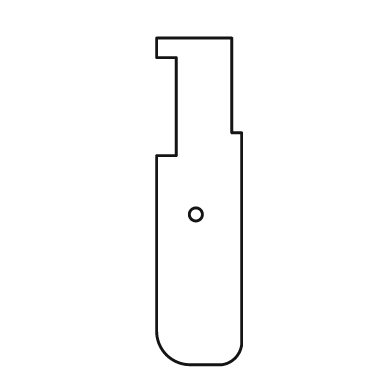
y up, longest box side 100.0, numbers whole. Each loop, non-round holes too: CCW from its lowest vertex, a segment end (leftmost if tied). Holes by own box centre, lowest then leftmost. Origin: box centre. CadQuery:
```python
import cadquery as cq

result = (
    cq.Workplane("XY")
    .moveTo(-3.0, -50.0)
    .lineTo(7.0, -50.0)
    .threePointArc((11.0, -48.0), (13.0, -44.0))
    .lineTo(13.0, 21.0)
    .lineTo(10.0, 21.0)
    .lineTo(10.0, 50.0)
    .lineTo(-13.0, 50.0)
    .lineTo(-13.0, 44.0)
    .lineTo(-7.0, 44.0)
    .lineTo(-7.0, 14.0)
    .lineTo(-13.0, 14.0)
    .lineTo(-13.0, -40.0)
    .threePointArc((-10.0, -47.0), (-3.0, -50.0))
    .close()
    .moveTo(-1.0, -4.0)
    .circle(2.0)
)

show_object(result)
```